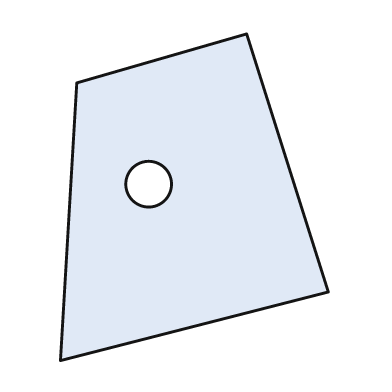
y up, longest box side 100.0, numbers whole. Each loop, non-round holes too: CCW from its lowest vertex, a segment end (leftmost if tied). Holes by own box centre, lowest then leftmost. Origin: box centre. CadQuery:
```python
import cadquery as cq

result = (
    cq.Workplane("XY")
    .moveTo(-41.0, -50.0)
    .lineTo(41.0, -29.0)
    .lineTo(16.0, 50.0)
    .lineTo(-36.0, 35.0)
    .close()
    .moveTo(-14.0, 4.0)
    .circle(7.0)
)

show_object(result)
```